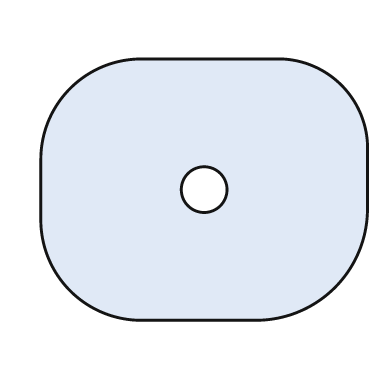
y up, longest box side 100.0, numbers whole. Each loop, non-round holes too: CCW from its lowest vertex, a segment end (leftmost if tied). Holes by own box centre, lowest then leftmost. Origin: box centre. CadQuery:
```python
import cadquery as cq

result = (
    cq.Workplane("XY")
    .moveTo(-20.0, -40.0)
    .lineTo(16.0, -40.0)
    .threePointArc((40.0, -30.0), (50.0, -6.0))
    .lineTo(50.0, 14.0)
    .threePointArc((42.0, 32.0), (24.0, 40.0))
    .lineTo(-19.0, 40.0)
    .threePointArc((-41.0, 31.0), (-50.0, 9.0))
    .lineTo(-50.0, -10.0)
    .threePointArc((-41.0, -31.0), (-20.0, -40.0))
    .close()
    .moveTo(0.0, 0.0)
    .circle(7.0)
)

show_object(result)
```